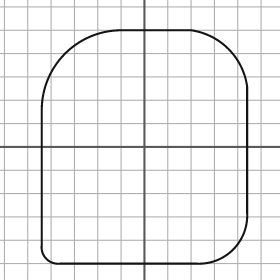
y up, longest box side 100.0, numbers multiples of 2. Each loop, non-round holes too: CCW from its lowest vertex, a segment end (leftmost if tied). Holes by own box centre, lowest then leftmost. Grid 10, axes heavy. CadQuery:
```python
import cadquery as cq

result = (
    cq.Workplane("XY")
    .moveTo(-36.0, -50.0)
    .lineTo(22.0, -50.0)
    .threePointArc((38.0, -44.0), (44.0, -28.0))
    .lineTo(44.0, 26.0)
    .threePointArc((36.0, 42.0), (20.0, 50.0))
    .lineTo(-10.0, 50.0)
    .threePointArc((-34.0, 40.0), (-44.0, 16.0))
    .lineTo(-44.0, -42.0)
    .threePointArc((-42.0, -48.0), (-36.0, -50.0))
    .close()
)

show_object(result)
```